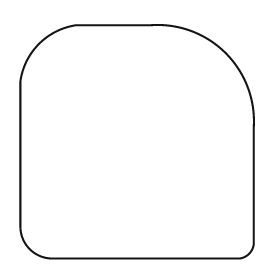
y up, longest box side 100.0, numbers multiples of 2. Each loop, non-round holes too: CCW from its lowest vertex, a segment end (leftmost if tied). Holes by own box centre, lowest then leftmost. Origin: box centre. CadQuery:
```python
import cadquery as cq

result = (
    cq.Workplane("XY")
    .moveTo(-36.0, -50.0)
    .lineTo(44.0, -50.0)
    .threePointArc((48.0, -48.0), (50.0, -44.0))
    .lineTo(50.0, 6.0)
    .threePointArc((38.0, 38.0), (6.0, 50.0))
    .lineTo(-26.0, 50.0)
    .threePointArc((-42.0, 42.0), (-50.0, 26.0))
    .lineTo(-50.0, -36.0)
    .threePointArc((-46.0, -46.0), (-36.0, -50.0))
    .close()
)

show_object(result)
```